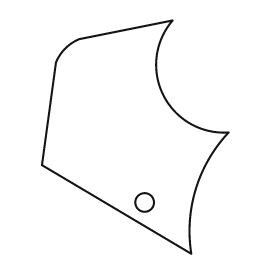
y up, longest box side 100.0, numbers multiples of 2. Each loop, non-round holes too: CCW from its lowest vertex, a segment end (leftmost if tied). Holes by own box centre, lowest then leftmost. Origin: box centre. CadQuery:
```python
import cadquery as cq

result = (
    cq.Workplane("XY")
    .moveTo(24.0, -50.0)
    .threePointArc((26.0, -22.0), (40.0, 2.0))
    .threePointArc((12.0, 18.0), (16.0, 50.0))
    .lineTo(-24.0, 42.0)
    .threePointArc((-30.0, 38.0), (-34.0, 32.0))
    .lineTo(-40.0, -12.0)
    .close()
    .moveTo(4.0, -28.0)
    .circle(4.0)
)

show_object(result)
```